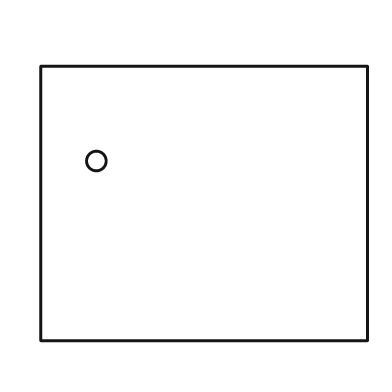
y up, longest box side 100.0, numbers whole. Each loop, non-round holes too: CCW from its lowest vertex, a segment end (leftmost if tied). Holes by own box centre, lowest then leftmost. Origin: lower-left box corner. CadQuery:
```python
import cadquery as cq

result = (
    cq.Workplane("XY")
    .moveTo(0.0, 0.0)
    .lineTo(100.0, 0.0)
    .lineTo(100.0, 84.0)
    .lineTo(0.0, 84.0)
    .close()
    .moveTo(17.0, 55.0)
    .circle(3.0)
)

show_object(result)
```